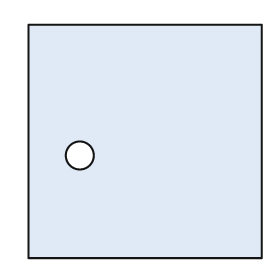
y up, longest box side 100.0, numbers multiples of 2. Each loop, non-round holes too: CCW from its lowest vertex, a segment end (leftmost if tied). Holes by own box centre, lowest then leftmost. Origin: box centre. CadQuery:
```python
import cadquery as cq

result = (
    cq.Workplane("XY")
    .moveTo(-50.0, -50.0)
    .lineTo(50.0, -50.0)
    .lineTo(50.0, 50.0)
    .lineTo(-50.0, 50.0)
    .close()
    .moveTo(-28.0, -6.0)
    .circle(6.0)
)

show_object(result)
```